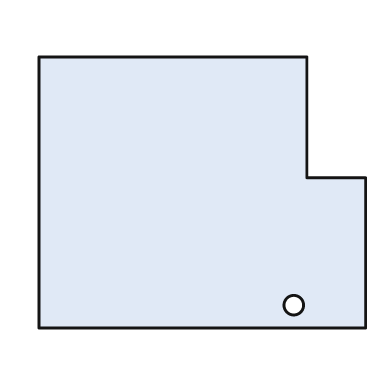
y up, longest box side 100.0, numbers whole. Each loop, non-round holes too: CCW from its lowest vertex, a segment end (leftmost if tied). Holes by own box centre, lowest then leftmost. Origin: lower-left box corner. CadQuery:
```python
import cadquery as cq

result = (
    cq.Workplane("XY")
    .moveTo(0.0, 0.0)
    .lineTo(100.0, 0.0)
    .lineTo(100.0, 46.0)
    .lineTo(82.0, 46.0)
    .lineTo(82.0, 83.0)
    .lineTo(0.0, 83.0)
    .close()
    .moveTo(78.0, 7.0)
    .circle(3.0)
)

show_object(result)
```